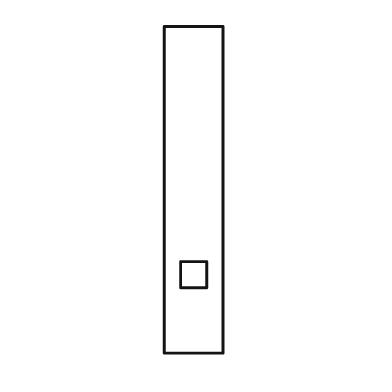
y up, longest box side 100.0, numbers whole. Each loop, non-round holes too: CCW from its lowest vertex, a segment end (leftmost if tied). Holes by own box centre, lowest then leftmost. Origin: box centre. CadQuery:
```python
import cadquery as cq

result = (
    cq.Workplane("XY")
    .moveTo(-9.0, -50.0)
    .lineTo(9.0, -50.0)
    .lineTo(9.0, 50.0)
    .lineTo(-9.0, 50.0)
    .close()
    .moveTo(-4.0, -30.0)
    .lineTo(4.0, -30.0)
    .lineTo(4.0, -22.0)
    .lineTo(-4.0, -22.0)
    .close()
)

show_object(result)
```